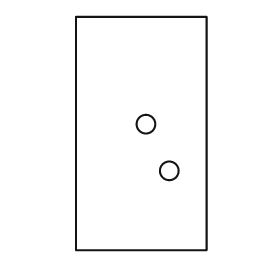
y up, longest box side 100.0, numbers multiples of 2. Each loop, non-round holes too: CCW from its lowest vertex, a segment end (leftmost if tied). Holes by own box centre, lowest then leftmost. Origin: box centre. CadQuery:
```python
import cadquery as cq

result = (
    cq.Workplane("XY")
    .moveTo(-28.0, -50.0)
    .lineTo(28.0, -50.0)
    .lineTo(28.0, 50.0)
    .lineTo(-28.0, 50.0)
    .close()
    .moveTo(12.0, -16.0)
    .circle(4.0)
    .moveTo(2.0, 4.0)
    .circle(4.0)
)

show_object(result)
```